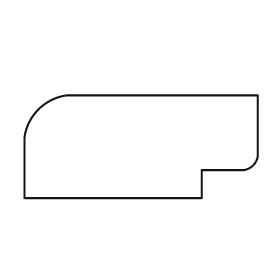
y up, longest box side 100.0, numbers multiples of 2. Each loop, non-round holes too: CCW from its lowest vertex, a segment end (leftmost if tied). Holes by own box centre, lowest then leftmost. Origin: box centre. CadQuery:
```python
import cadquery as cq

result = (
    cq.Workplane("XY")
    .moveTo(-50.0, -22.0)
    .lineTo(26.0, -22.0)
    .lineTo(26.0, -10.0)
    .lineTo(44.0, -10.0)
    .threePointArc((48.0, -8.0), (50.0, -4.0))
    .lineTo(50.0, 22.0)
    .lineTo(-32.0, 22.0)
    .threePointArc((-44.0, 16.0), (-50.0, 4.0))
    .close()
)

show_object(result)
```